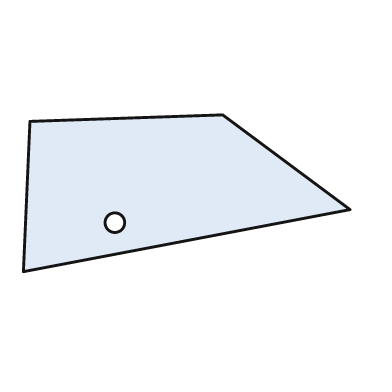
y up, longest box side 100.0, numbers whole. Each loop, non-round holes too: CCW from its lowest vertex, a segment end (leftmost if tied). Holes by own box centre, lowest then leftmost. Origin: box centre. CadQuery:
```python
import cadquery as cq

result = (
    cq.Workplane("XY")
    .moveTo(-50.0, -24.0)
    .lineTo(50.0, -5.0)
    .lineTo(11.0, 24.0)
    .lineTo(-48.0, 22.0)
    .close()
    .moveTo(-22.0, -9.0)
    .circle(3.0)
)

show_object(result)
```